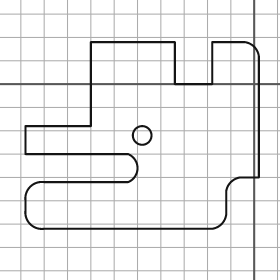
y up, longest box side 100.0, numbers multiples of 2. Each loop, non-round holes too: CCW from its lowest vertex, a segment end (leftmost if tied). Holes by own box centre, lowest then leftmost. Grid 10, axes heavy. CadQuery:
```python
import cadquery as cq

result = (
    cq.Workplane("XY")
    .moveTo(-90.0, -62.0)
    .lineTo(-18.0, -62.0)
    .threePointArc((-14.0, -60.0), (-12.0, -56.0))
    .lineTo(-12.0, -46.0)
    .threePointArc((-10.0, -42.0), (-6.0, -40.0))
    .lineTo(2.0, -40.0)
    .lineTo(2.0, 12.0)
    .threePointArc((0.0, 16.0), (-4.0, 18.0))
    .lineTo(-18.0, 18.0)
    .lineTo(-18.0, 0.0)
    .lineTo(-34.0, 0.0)
    .lineTo(-34.0, 18.0)
    .lineTo(-70.0, 18.0)
    .lineTo(-70.0, -18.0)
    .lineTo(-98.0, -18.0)
    .lineTo(-98.0, -30.0)
    .lineTo(-54.0, -30.0)
    .threePointArc((-50.0, -36.0), (-54.0, -42.0))
    .lineTo(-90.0, -42.0)
    .threePointArc((-96.0, -44.0), (-98.0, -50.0))
    .lineTo(-98.0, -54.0)
    .threePointArc((-96.0, -60.0), (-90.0, -62.0))
    .close()
    .moveTo(-48.0, -22.0)
    .circle(4.0)
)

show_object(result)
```